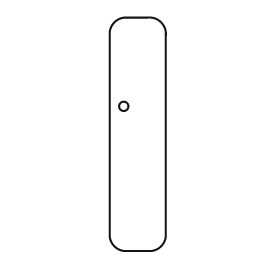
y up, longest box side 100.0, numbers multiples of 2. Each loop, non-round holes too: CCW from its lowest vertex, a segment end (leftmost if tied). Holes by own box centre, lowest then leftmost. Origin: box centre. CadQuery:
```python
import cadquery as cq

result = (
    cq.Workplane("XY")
    .moveTo(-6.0, -50.0)
    .lineTo(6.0, -50.0)
    .threePointArc((10.0, -48.0), (12.0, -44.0))
    .lineTo(12.0, 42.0)
    .threePointArc((10.0, 48.0), (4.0, 50.0))
    .lineTo(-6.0, 50.0)
    .threePointArc((-10.0, 48.0), (-12.0, 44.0))
    .lineTo(-12.0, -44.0)
    .threePointArc((-10.0, -48.0), (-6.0, -50.0))
    .close()
    .moveTo(-6.0, 12.0)
    .circle(2.0)
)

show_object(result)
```